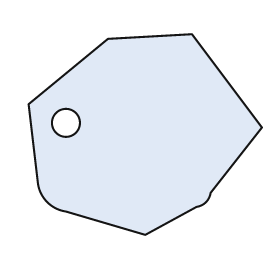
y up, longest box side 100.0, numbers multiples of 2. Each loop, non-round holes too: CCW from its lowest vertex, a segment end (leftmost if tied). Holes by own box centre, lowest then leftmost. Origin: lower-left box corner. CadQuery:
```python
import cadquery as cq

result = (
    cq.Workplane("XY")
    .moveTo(50.0, 0.0)
    .lineTo(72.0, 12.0)
    .threePointArc((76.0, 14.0), (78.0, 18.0))
    .lineTo(100.0, 46.0)
    .lineTo(70.0, 86.0)
    .lineTo(34.0, 84.0)
    .lineTo(0.0, 56.0)
    .lineTo(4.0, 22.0)
    .threePointArc((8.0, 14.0), (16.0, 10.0))
    .close()
    .moveTo(16.0, 48.0)
    .circle(6.0)
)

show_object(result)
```